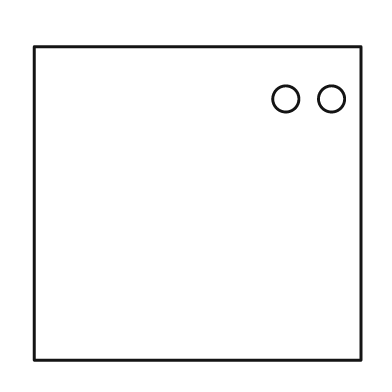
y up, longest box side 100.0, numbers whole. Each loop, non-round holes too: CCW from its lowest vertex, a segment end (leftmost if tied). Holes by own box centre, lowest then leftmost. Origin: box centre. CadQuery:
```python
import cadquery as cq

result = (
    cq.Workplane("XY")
    .moveTo(-50.0, -48.0)
    .lineTo(50.0, -48.0)
    .lineTo(50.0, 48.0)
    .lineTo(-50.0, 48.0)
    .close()
    .moveTo(27.0, 32.0)
    .circle(4.0)
    .moveTo(41.0, 32.0)
    .circle(4.0)
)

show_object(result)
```